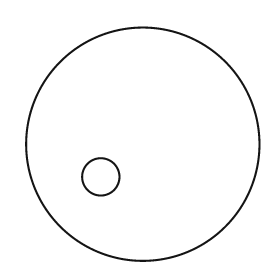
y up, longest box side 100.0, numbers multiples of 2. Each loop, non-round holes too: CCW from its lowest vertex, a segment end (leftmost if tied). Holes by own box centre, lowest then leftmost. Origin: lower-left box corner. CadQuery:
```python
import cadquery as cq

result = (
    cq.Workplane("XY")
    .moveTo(50.0, 50.0)
    .circle(50.0)
    .moveTo(32.0, 36.0)
    .circle(8.0)
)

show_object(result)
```